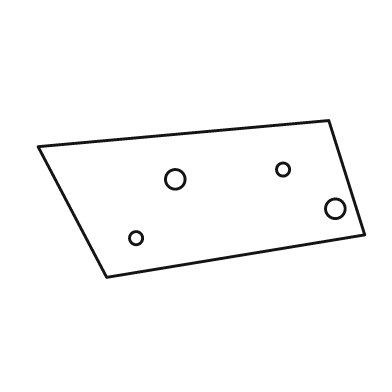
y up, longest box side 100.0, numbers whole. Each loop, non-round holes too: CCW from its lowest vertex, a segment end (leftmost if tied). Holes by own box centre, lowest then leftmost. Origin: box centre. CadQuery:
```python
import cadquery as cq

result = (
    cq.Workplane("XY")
    .moveTo(-29.0, -24.0)
    .lineTo(50.0, -11.0)
    .lineTo(39.0, 24.0)
    .lineTo(-50.0, 16.0)
    .close()
    .moveTo(-20.0, -12.0)
    .circle(2.0)
    .moveTo(41.0, -3.0)
    .circle(3.0)
    .moveTo(-8.0, 6.0)
    .circle(3.0)
    .moveTo(25.0, 9.0)
    .circle(2.0)
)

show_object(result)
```